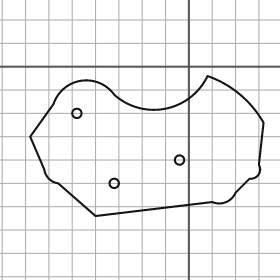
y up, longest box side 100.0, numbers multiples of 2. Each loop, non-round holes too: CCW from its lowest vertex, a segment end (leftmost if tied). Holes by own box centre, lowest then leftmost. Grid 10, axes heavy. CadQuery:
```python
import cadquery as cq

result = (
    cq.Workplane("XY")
    .moveTo(-40.0, -64.0)
    .lineTo(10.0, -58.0)
    .threePointArc((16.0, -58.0), (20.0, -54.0))
    .lineTo(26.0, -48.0)
    .threePointArc((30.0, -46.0), (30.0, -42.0))
    .lineTo(32.0, -24.0)
    .threePointArc((22.0, -12.0), (8.0, -4.0))
    .threePointArc((-10.0, -18.0), (-32.0, -12.0))
    .threePointArc((-46.0, -6.0), (-58.0, -16.0))
    .lineTo(-68.0, -30.0)
    .lineTo(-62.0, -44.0)
    .threePointArc((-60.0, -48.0), (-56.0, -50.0))
    .close()
    .moveTo(-32.0, -50.0)
    .circle(2.0)
    .moveTo(-4.0, -40.0)
    .circle(2.0)
    .moveTo(-48.0, -20.0)
    .circle(2.0)
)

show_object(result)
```